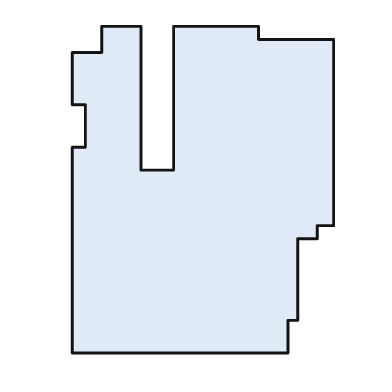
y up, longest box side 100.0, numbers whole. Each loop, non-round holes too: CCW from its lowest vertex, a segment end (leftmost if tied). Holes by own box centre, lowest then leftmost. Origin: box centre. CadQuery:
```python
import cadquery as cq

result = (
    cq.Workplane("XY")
    .moveTo(-40.0, -50.0)
    .lineTo(26.0, -50.0)
    .lineTo(26.0, -40.0)
    .lineTo(29.0, -40.0)
    .lineTo(29.0, -15.0)
    .lineTo(35.0, -15.0)
    .lineTo(35.0, -11.0)
    .lineTo(40.0, -11.0)
    .lineTo(40.0, 46.0)
    .lineTo(17.0, 46.0)
    .lineTo(17.0, 50.0)
    .lineTo(-9.0, 50.0)
    .lineTo(-9.0, 6.0)
    .lineTo(-19.0, 6.0)
    .lineTo(-19.0, 50.0)
    .lineTo(-31.0, 50.0)
    .lineTo(-31.0, 42.0)
    .lineTo(-40.0, 42.0)
    .lineTo(-40.0, 26.0)
    .lineTo(-36.0, 26.0)
    .lineTo(-36.0, 13.0)
    .lineTo(-40.0, 13.0)
    .close()
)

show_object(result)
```